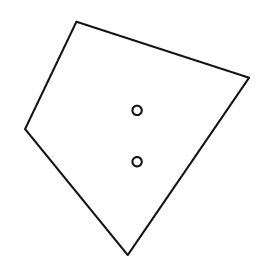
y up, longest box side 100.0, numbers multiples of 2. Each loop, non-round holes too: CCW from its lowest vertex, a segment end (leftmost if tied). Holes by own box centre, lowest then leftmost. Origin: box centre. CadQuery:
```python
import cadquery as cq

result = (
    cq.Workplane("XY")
    .moveTo(-4.0, -50.0)
    .lineTo(48.0, 26.0)
    .lineTo(-26.0, 50.0)
    .lineTo(-48.0, 4.0)
    .close()
    .moveTo(0.0, -10.0)
    .circle(2.0)
    .moveTo(0.0, 12.0)
    .circle(2.0)
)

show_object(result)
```